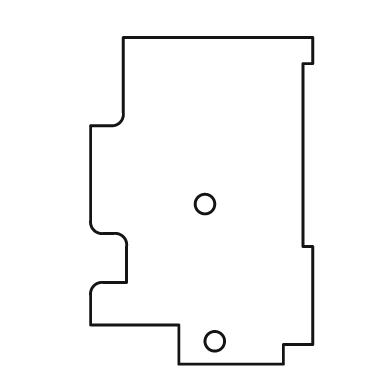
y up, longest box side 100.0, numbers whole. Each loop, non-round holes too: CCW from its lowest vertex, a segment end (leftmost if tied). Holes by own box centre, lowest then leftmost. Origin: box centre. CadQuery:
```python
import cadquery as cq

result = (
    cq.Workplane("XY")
    .moveTo(-7.0, -50.0)
    .lineTo(25.0, -50.0)
    .lineTo(25.0, -44.0)
    .lineTo(34.0, -44.0)
    .lineTo(34.0, -14.0)
    .lineTo(31.0, -14.0)
    .lineTo(31.0, 42.0)
    .lineTo(34.0, 42.0)
    .lineTo(34.0, 50.0)
    .lineTo(-24.0, 50.0)
    .lineTo(-24.0, 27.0)
    .threePointArc((-25.0, 24.0), (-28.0, 23.0))
    .lineTo(-34.0, 23.0)
    .lineTo(-34.0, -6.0)
    .threePointArc((-33.0, -9.0), (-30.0, -10.0))
    .lineTo(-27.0, -10.0)
    .threePointArc((-24.0, -11.0), (-23.0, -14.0))
    .lineTo(-23.0, -25.0)
    .lineTo(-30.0, -25.0)
    .threePointArc((-33.0, -26.0), (-34.0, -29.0))
    .lineTo(-34.0, -38.0)
    .lineTo(-7.0, -38.0)
    .close()
    .moveTo(4.0, -43.0)
    .circle(3.0)
    .moveTo(1.0, -1.0)
    .circle(3.0)
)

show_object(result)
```